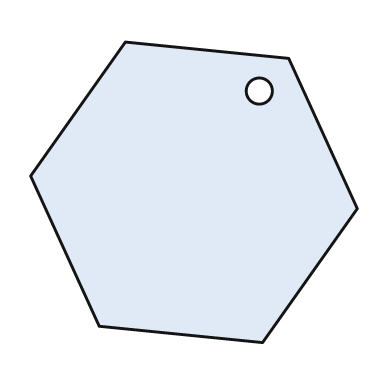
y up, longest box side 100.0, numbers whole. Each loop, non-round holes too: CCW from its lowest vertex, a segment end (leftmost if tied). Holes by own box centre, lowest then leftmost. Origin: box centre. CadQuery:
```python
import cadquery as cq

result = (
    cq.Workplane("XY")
    .moveTo(21.0, -46.0)
    .lineTo(50.0, -5.0)
    .lineTo(29.0, 41.0)
    .lineTo(-21.0, 46.0)
    .lineTo(-50.0, 5.0)
    .lineTo(-29.0, -41.0)
    .close()
    .moveTo(20.0, 31.0)
    .circle(4.0)
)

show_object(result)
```